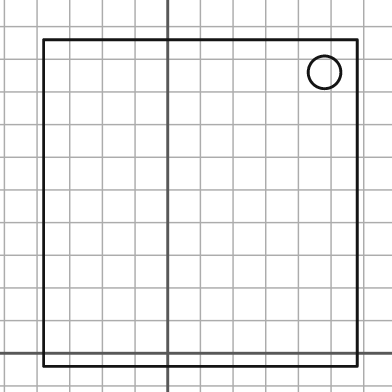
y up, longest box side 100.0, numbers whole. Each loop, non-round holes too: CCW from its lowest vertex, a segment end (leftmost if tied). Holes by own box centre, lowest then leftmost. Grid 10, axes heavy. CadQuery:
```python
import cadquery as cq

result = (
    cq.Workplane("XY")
    .moveTo(-38.0, -4.0)
    .lineTo(58.0, -4.0)
    .lineTo(58.0, 96.0)
    .lineTo(-38.0, 96.0)
    .close()
    .moveTo(48.0, 86.0)
    .circle(5.0)
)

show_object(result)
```